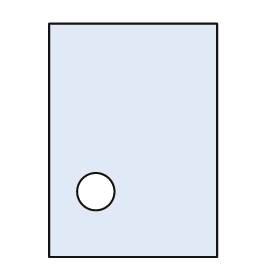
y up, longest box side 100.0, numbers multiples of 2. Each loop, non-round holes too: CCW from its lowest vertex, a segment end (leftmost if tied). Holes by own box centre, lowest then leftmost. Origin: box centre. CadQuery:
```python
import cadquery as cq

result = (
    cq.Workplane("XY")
    .moveTo(-36.0, -50.0)
    .lineTo(36.0, -50.0)
    .lineTo(36.0, 50.0)
    .lineTo(-36.0, 50.0)
    .close()
    .moveTo(-16.0, -22.0)
    .circle(8.0)
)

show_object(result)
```